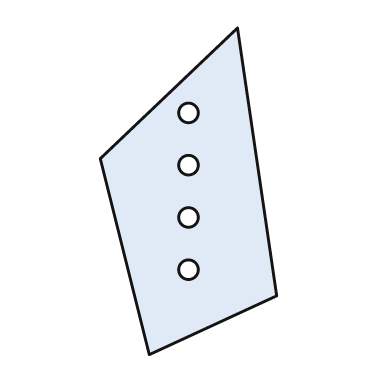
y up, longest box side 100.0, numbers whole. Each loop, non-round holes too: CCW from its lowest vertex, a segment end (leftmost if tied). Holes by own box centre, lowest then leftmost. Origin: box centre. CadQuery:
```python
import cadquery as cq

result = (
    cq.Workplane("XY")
    .moveTo(-12.0, -50.0)
    .lineTo(27.0, -32.0)
    .lineTo(15.0, 50.0)
    .lineTo(-27.0, 10.0)
    .close()
    .moveTo(0.0, -24.0)
    .circle(3.0)
    .moveTo(0.0, -8.0)
    .circle(3.0)
    .moveTo(0.0, 8.0)
    .circle(3.0)
    .moveTo(0.0, 24.0)
    .circle(3.0)
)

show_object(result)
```